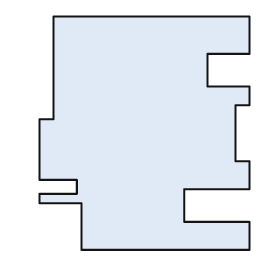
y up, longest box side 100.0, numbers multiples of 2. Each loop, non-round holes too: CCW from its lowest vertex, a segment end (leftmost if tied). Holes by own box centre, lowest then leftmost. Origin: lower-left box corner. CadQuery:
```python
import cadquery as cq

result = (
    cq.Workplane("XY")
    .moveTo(18.0, 0.0)
    .lineTo(90.0, 0.0)
    .lineTo(90.0, 12.0)
    .lineTo(62.0, 12.0)
    .lineTo(62.0, 26.0)
    .lineTo(90.0, 26.0)
    .lineTo(90.0, 38.0)
    .lineTo(84.0, 38.0)
    .lineTo(84.0, 62.0)
    .lineTo(90.0, 62.0)
    .lineTo(90.0, 70.0)
    .lineTo(72.0, 70.0)
    .lineTo(72.0, 84.0)
    .lineTo(90.0, 84.0)
    .lineTo(90.0, 100.0)
    .lineTo(6.0, 100.0)
    .lineTo(6.0, 56.0)
    .lineTo(0.0, 56.0)
    .lineTo(0.0, 30.0)
    .lineTo(16.0, 30.0)
    .lineTo(16.0, 24.0)
    .lineTo(0.0, 24.0)
    .lineTo(0.0, 20.0)
    .lineTo(18.0, 20.0)
    .close()
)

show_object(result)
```